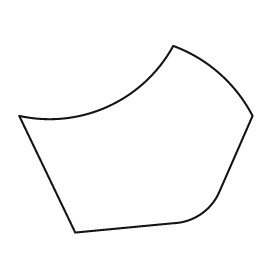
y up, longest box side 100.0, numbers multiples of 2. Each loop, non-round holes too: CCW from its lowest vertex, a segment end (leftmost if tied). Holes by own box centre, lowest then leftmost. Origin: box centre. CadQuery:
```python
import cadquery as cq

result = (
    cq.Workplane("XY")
    .moveTo(-26.0, -40.0)
    .lineTo(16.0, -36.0)
    .threePointArc((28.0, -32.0), (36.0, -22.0))
    .lineTo(50.0, 10.0)
    .threePointArc((36.0, 28.0), (16.0, 40.0))
    .threePointArc((-12.0, 14.0), (-50.0, 10.0))
    .close()
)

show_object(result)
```